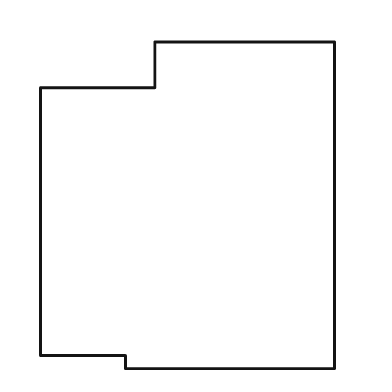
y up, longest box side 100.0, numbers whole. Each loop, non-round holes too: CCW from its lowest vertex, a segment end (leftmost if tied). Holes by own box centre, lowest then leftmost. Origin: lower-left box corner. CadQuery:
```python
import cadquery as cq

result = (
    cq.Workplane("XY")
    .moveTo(26.0, 0.0)
    .lineTo(90.0, 0.0)
    .lineTo(90.0, 100.0)
    .lineTo(35.0, 100.0)
    .lineTo(35.0, 86.0)
    .lineTo(0.0, 86.0)
    .lineTo(0.0, 4.0)
    .lineTo(26.0, 4.0)
    .close()
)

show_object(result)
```